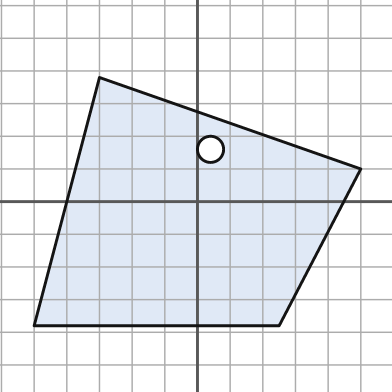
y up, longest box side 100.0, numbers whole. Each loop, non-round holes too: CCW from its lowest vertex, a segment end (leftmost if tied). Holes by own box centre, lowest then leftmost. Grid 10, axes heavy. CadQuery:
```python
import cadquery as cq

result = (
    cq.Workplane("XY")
    .moveTo(-50.0, -38.0)
    .lineTo(25.0, -38.0)
    .lineTo(50.0, 10.0)
    .lineTo(-30.0, 38.0)
    .close()
    .moveTo(4.0, 16.0)
    .circle(4.0)
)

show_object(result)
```